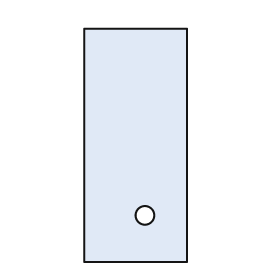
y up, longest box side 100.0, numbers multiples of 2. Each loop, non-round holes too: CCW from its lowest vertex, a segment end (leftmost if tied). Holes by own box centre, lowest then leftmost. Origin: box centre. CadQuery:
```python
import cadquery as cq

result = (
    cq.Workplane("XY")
    .moveTo(-22.0, -50.0)
    .lineTo(22.0, -50.0)
    .lineTo(22.0, 50.0)
    .lineTo(-22.0, 50.0)
    .close()
    .moveTo(4.0, -30.0)
    .circle(4.0)
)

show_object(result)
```